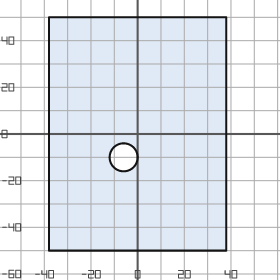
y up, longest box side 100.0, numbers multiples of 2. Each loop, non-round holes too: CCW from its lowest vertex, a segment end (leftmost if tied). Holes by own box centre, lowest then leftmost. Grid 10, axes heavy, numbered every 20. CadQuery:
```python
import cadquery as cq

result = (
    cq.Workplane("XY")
    .moveTo(-38.0, -50.0)
    .lineTo(38.0, -50.0)
    .lineTo(38.0, 50.0)
    .lineTo(-38.0, 50.0)
    .close()
    .moveTo(-6.0, -10.0)
    .circle(6.0)
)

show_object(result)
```